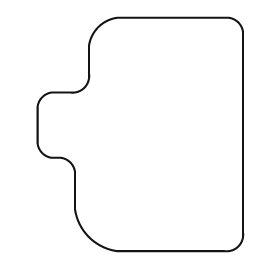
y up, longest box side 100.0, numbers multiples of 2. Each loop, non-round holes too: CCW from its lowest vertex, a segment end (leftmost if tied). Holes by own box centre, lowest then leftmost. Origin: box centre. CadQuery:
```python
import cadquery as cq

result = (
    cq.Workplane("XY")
    .moveTo(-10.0, -50.0)
    .lineTo(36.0, -50.0)
    .threePointArc((42.0, -48.0), (44.0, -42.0))
    .lineTo(44.0, 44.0)
    .threePointArc((42.0, 48.0), (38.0, 50.0))
    .lineTo(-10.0, 50.0)
    .threePointArc((-18.0, 46.0), (-22.0, 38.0))
    .lineTo(-22.0, 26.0)
    .threePointArc((-24.0, 20.0), (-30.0, 18.0))
    .lineTo(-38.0, 18.0)
    .threePointArc((-42.0, 16.0), (-44.0, 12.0))
    .lineTo(-44.0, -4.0)
    .threePointArc((-42.0, -8.0), (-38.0, -10.0))
    .lineTo(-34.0, -10.0)
    .threePointArc((-30.0, -12.0), (-28.0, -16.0))
    .lineTo(-28.0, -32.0)
    .threePointArc((-22.0, -44.0), (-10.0, -50.0))
    .close()
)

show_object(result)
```